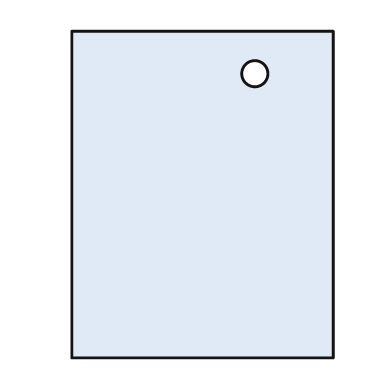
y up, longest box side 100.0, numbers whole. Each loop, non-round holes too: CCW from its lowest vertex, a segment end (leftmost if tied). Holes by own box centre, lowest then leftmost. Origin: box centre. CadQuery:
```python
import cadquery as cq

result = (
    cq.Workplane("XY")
    .moveTo(-40.0, -50.0)
    .lineTo(40.0, -50.0)
    .lineTo(40.0, 50.0)
    .lineTo(-40.0, 50.0)
    .close()
    .moveTo(16.0, 37.0)
    .circle(4.0)
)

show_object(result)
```